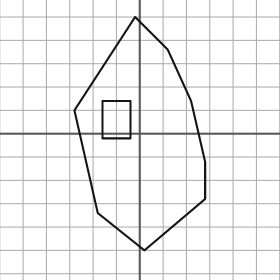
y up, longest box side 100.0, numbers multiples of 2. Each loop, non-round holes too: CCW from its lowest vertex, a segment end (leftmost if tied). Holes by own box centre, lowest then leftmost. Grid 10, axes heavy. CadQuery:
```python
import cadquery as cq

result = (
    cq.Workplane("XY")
    .moveTo(2.0, -50.0)
    .lineTo(28.0, -28.0)
    .lineTo(28.0, -12.0)
    .lineTo(22.0, 14.0)
    .lineTo(12.0, 36.0)
    .lineTo(-2.0, 50.0)
    .lineTo(-28.0, 10.0)
    .lineTo(-18.0, -34.0)
    .close()
    .moveTo(-16.0, -2.0)
    .lineTo(-4.0, -2.0)
    .lineTo(-4.0, 14.0)
    .lineTo(-16.0, 14.0)
    .close()
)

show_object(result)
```